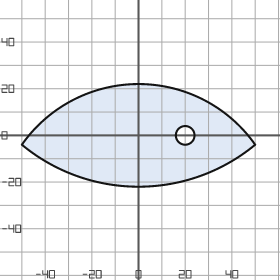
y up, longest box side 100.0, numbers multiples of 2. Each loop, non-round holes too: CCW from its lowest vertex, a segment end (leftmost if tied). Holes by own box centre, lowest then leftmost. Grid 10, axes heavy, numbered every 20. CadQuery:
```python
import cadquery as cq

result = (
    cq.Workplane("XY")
    .moveTo(-50.0, -4.0)
    .threePointArc((0.0, -22.0), (50.0, -4.0))
    .threePointArc((0.0, 22.0), (-50.0, -4.0))
    .close()
    .moveTo(20.0, 0.0)
    .circle(4.0)
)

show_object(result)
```